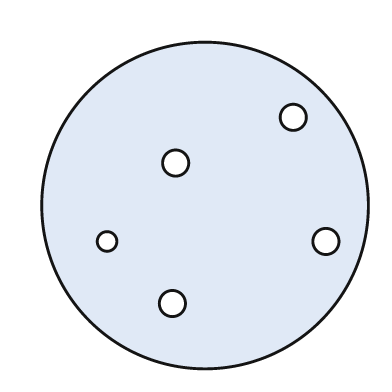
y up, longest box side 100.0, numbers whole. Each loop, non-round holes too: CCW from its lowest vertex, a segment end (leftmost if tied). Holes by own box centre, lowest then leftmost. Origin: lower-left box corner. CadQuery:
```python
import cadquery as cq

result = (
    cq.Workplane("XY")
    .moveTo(50.0, 50.0)
    .circle(50.0)
    .moveTo(40.0, 20.0)
    .circle(4.0)
    .moveTo(20.0, 39.0)
    .circle(3.0)
    .moveTo(87.0, 39.0)
    .circle(4.0)
    .moveTo(41.0, 63.0)
    .circle(4.0)
    .moveTo(77.0, 77.0)
    .circle(4.0)
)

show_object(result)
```